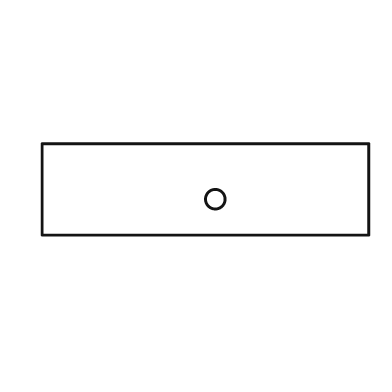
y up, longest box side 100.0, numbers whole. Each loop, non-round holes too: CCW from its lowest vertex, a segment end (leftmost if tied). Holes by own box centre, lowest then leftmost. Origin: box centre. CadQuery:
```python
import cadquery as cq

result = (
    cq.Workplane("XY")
    .moveTo(-50.0, -14.0)
    .lineTo(50.0, -14.0)
    .lineTo(50.0, 14.0)
    .lineTo(-50.0, 14.0)
    .close()
    .moveTo(3.0, -3.0)
    .circle(3.0)
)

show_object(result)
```